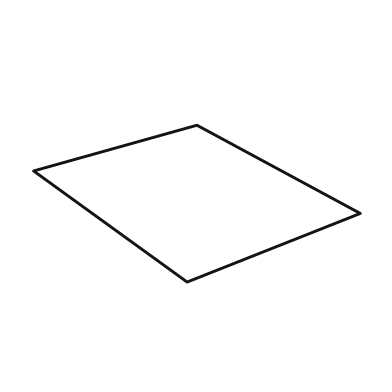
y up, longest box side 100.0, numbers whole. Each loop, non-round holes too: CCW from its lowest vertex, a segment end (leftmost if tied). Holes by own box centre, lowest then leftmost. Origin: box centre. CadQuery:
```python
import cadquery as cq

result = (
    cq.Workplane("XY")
    .moveTo(-3.0, -24.0)
    .lineTo(50.0, -3.0)
    .lineTo(0.0, 24.0)
    .lineTo(-50.0, 10.0)
    .close()
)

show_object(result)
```